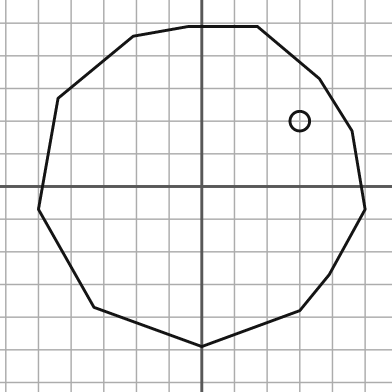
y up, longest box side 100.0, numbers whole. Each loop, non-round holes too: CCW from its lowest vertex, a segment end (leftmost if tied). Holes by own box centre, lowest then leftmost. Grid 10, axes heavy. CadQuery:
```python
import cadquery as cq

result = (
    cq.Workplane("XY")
    .moveTo(0.0, -49.0)
    .lineTo(30.0, -38.0)
    .lineTo(39.0, -27.0)
    .lineTo(50.0, -7.0)
    .lineTo(46.0, 17.0)
    .lineTo(36.0, 33.0)
    .lineTo(17.0, 49.0)
    .lineTo(-4.0, 49.0)
    .lineTo(-21.0, 46.0)
    .lineTo(-44.0, 27.0)
    .lineTo(-50.0, -7.0)
    .lineTo(-33.0, -37.0)
    .close()
    .moveTo(30.0, 20.0)
    .circle(3.0)
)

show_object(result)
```